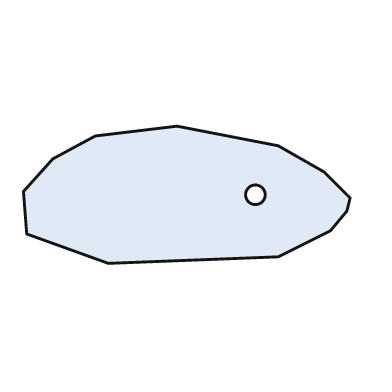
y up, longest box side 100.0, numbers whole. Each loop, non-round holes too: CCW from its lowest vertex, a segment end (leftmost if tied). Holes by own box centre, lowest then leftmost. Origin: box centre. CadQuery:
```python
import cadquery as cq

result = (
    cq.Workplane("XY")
    .moveTo(-24.0, -21.0)
    .lineTo(28.0, -19.0)
    .lineTo(44.0, -11.0)
    .lineTo(49.0, -5.0)
    .lineTo(50.0, -1.0)
    .lineTo(42.0, 7.0)
    .lineTo(28.0, 15.0)
    .lineTo(-3.0, 21.0)
    .lineTo(-28.0, 18.0)
    .lineTo(-41.0, 11.0)
    .lineTo(-50.0, 1.0)
    .lineTo(-49.0, -12.0)
    .close()
    .moveTo(21.0, 0.0)
    .circle(3.0)
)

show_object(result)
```